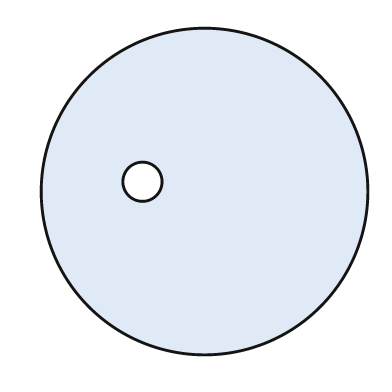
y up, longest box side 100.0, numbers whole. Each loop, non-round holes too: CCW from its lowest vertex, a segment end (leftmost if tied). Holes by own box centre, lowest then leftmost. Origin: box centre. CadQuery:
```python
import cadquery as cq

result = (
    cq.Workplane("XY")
    .moveTo(0.0, 0.0)
    .circle(50.0)
    .moveTo(-19.0, 3.0)
    .circle(6.0)
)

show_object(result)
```